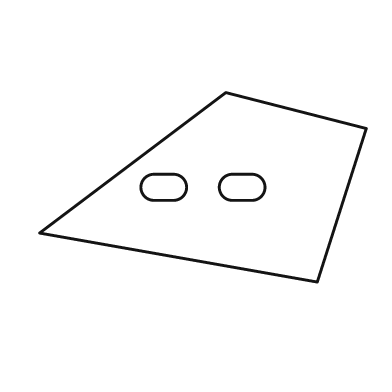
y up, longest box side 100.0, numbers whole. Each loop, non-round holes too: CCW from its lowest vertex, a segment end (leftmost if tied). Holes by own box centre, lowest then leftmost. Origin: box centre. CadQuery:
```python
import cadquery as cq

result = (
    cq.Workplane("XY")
    .moveTo(35.0, -29.0)
    .lineTo(50.0, 18.0)
    .lineTo(7.0, 29.0)
    .lineTo(-50.0, -14.0)
    .close()
    .moveTo(-15.0, -4.0)
    .lineTo(-9.0, -4.0)
    .threePointArc((-5.0, 0.0), (-9.0, 4.0))
    .lineTo(-15.0, 4.0)
    .threePointArc((-19.0, 0.0), (-15.0, -4.0))
    .close()
    .moveTo(9.0, -4.0)
    .lineTo(15.0, -4.0)
    .threePointArc((19.0, 0.0), (15.0, 4.0))
    .lineTo(9.0, 4.0)
    .threePointArc((5.0, 0.0), (9.0, -4.0))
    .close()
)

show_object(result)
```